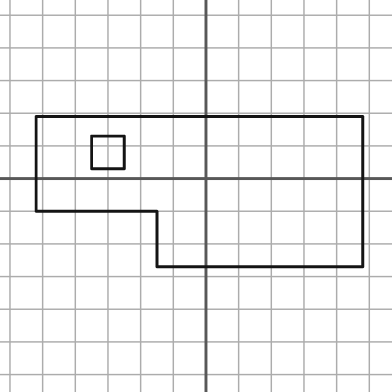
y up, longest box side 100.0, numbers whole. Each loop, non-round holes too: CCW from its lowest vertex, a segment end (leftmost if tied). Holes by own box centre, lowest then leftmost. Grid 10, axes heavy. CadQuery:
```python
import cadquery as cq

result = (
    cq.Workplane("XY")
    .moveTo(-15.0, -27.0)
    .lineTo(48.0, -27.0)
    .lineTo(48.0, 19.0)
    .lineTo(-52.0, 19.0)
    .lineTo(-52.0, -10.0)
    .lineTo(-15.0, -10.0)
    .close()
    .moveTo(-35.0, 3.0)
    .lineTo(-25.0, 3.0)
    .lineTo(-25.0, 13.0)
    .lineTo(-35.0, 13.0)
    .close()
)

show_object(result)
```